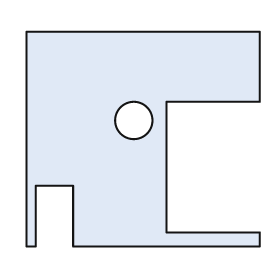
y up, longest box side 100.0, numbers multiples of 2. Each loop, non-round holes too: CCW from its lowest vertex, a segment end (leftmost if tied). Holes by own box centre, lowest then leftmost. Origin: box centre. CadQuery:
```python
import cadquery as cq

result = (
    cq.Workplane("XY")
    .moveTo(-50.0, -46.0)
    .lineTo(-46.0, -46.0)
    .lineTo(-46.0, -20.0)
    .lineTo(-30.0, -20.0)
    .lineTo(-30.0, -46.0)
    .lineTo(50.0, -46.0)
    .lineTo(50.0, -40.0)
    .lineTo(10.0, -40.0)
    .lineTo(10.0, 16.0)
    .lineTo(50.0, 16.0)
    .lineTo(50.0, 46.0)
    .lineTo(-50.0, 46.0)
    .close()
    .moveTo(-4.0, 8.0)
    .circle(8.0)
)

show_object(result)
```